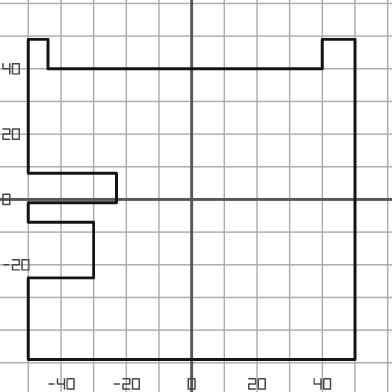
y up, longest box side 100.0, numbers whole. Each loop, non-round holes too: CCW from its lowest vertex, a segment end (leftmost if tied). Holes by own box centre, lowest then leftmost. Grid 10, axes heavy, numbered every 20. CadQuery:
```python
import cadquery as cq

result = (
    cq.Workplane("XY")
    .moveTo(-50.0, -49.0)
    .lineTo(50.0, -49.0)
    .lineTo(50.0, 49.0)
    .lineTo(40.0, 49.0)
    .lineTo(40.0, 40.0)
    .lineTo(-44.0, 40.0)
    .lineTo(-44.0, 49.0)
    .lineTo(-50.0, 49.0)
    .lineTo(-50.0, 8.0)
    .lineTo(-23.0, 8.0)
    .lineTo(-23.0, -1.0)
    .lineTo(-50.0, -1.0)
    .lineTo(-50.0, -7.0)
    .lineTo(-30.0, -7.0)
    .lineTo(-30.0, -24.0)
    .lineTo(-50.0, -24.0)
    .close()
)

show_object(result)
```